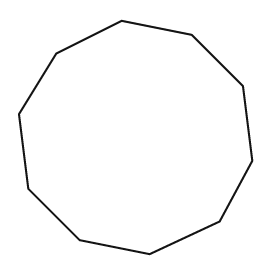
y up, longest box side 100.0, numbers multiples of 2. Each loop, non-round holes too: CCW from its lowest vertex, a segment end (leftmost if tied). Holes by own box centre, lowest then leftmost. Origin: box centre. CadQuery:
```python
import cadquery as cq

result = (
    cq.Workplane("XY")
    .moveTo(6.0, -50.0)
    .lineTo(36.0, -36.0)
    .lineTo(50.0, -10.0)
    .lineTo(46.0, 22.0)
    .lineTo(24.0, 44.0)
    .lineTo(-6.0, 50.0)
    .lineTo(-34.0, 36.0)
    .lineTo(-50.0, 10.0)
    .lineTo(-46.0, -22.0)
    .lineTo(-24.0, -44.0)
    .close()
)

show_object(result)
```